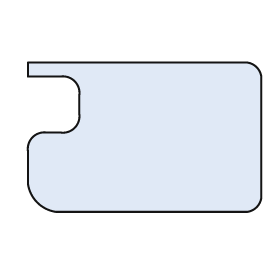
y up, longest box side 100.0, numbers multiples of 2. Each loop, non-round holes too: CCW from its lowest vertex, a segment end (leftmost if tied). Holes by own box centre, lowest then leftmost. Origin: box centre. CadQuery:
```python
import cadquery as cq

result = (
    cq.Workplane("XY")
    .moveTo(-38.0, -32.0)
    .lineTo(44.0, -32.0)
    .threePointArc((48.0, -30.0), (50.0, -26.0))
    .lineTo(50.0, 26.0)
    .threePointArc((48.0, 30.0), (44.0, 32.0))
    .lineTo(-50.0, 32.0)
    .lineTo(-50.0, 26.0)
    .lineTo(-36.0, 26.0)
    .threePointArc((-30.0, 24.0), (-28.0, 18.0))
    .lineTo(-28.0, 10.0)
    .threePointArc((-30.0, 4.0), (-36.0, 2.0))
    .lineTo(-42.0, 2.0)
    .threePointArc((-48.0, 0.0), (-50.0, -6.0))
    .lineTo(-50.0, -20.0)
    .threePointArc((-46.0, -28.0), (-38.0, -32.0))
    .close()
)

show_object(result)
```